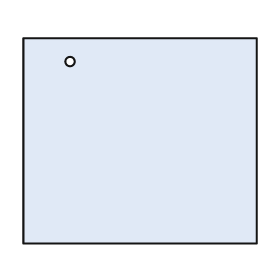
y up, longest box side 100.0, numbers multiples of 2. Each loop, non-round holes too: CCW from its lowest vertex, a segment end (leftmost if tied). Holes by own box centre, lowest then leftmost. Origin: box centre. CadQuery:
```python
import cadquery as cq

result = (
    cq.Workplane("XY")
    .moveTo(-50.0, -44.0)
    .lineTo(50.0, -44.0)
    .lineTo(50.0, 44.0)
    .lineTo(-50.0, 44.0)
    .close()
    .moveTo(-30.0, 34.0)
    .circle(2.0)
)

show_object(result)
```